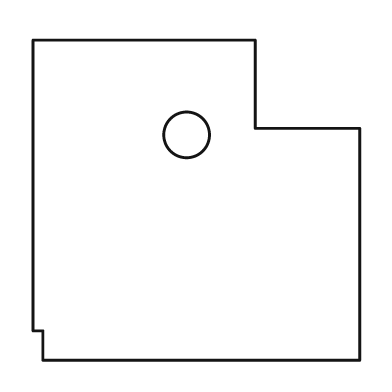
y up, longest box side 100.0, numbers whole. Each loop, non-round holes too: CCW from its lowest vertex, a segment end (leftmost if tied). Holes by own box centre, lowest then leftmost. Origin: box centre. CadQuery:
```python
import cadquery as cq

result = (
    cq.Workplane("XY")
    .moveTo(-47.0, -49.0)
    .lineTo(50.0, -49.0)
    .lineTo(50.0, 22.0)
    .lineTo(18.0, 22.0)
    .lineTo(18.0, 49.0)
    .lineTo(-50.0, 49.0)
    .lineTo(-50.0, -40.0)
    .lineTo(-47.0, -40.0)
    .close()
    .moveTo(-3.0, 20.0)
    .circle(7.0)
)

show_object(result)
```